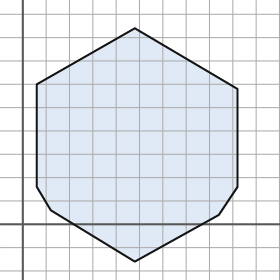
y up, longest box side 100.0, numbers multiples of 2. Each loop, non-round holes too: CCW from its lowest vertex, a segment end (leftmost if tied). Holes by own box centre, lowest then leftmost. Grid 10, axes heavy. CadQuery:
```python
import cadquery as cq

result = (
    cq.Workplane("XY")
    .moveTo(48.0, -16.0)
    .lineTo(84.0, 4.0)
    .lineTo(92.0, 16.0)
    .lineTo(92.0, 58.0)
    .lineTo(48.0, 84.0)
    .lineTo(6.0, 60.0)
    .lineTo(6.0, 16.0)
    .lineTo(12.0, 6.0)
    .close()
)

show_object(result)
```